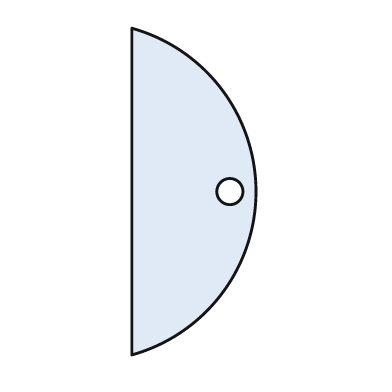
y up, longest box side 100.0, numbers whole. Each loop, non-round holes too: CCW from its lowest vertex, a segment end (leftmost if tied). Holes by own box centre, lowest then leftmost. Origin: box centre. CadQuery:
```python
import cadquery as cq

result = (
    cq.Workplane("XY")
    .moveTo(-19.0, -50.0)
    .threePointArc((19.0, 0.0), (-19.0, 50.0))
    .close()
    .moveTo(11.0, 0.0)
    .circle(4.0)
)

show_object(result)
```